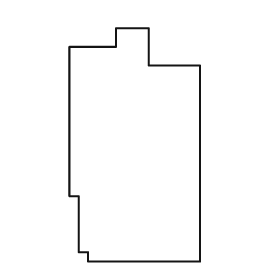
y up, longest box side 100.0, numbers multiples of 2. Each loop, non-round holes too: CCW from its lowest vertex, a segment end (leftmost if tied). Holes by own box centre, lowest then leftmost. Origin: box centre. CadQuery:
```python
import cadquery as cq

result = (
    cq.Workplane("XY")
    .moveTo(-20.0, -50.0)
    .lineTo(28.0, -50.0)
    .lineTo(28.0, 34.0)
    .lineTo(6.0, 34.0)
    .lineTo(6.0, 50.0)
    .lineTo(-8.0, 50.0)
    .lineTo(-8.0, 42.0)
    .lineTo(-28.0, 42.0)
    .lineTo(-28.0, -22.0)
    .lineTo(-24.0, -22.0)
    .lineTo(-24.0, -46.0)
    .lineTo(-20.0, -46.0)
    .close()
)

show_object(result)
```